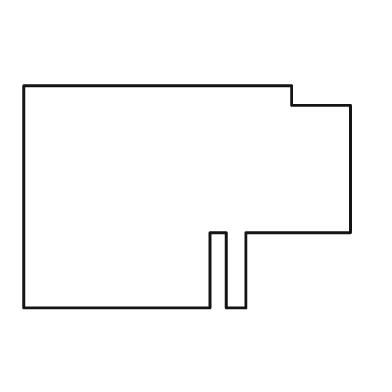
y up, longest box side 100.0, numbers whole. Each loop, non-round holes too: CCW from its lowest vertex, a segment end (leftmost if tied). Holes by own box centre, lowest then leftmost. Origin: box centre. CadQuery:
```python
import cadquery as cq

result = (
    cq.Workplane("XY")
    .moveTo(-50.0, -34.0)
    .lineTo(7.0, -34.0)
    .lineTo(7.0, -11.0)
    .lineTo(12.0, -11.0)
    .lineTo(12.0, -34.0)
    .lineTo(18.0, -34.0)
    .lineTo(18.0, -11.0)
    .lineTo(50.0, -11.0)
    .lineTo(50.0, 28.0)
    .lineTo(32.0, 28.0)
    .lineTo(32.0, 34.0)
    .lineTo(-50.0, 34.0)
    .close()
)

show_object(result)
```